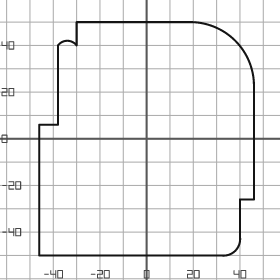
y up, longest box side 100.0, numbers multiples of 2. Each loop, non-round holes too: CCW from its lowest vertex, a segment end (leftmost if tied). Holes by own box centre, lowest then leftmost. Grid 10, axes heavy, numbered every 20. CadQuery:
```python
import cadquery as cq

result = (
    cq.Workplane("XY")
    .moveTo(-46.0, -50.0)
    .lineTo(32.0, -50.0)
    .threePointArc((38.0, -48.0), (40.0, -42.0))
    .lineTo(40.0, -26.0)
    .lineTo(46.0, -26.0)
    .lineTo(46.0, 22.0)
    .threePointArc((38.0, 42.0), (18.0, 50.0))
    .lineTo(-30.0, 50.0)
    .lineTo(-30.0, 40.0)
    .threePointArc((-34.0, 42.0), (-38.0, 40.0))
    .lineTo(-38.0, 6.0)
    .lineTo(-46.0, 6.0)
    .close()
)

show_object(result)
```